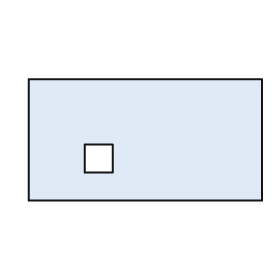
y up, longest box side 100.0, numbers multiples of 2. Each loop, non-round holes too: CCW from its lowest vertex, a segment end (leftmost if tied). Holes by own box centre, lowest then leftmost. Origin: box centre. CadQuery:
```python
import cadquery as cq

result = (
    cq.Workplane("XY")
    .moveTo(-50.0, -26.0)
    .lineTo(50.0, -26.0)
    .lineTo(50.0, 26.0)
    .lineTo(-50.0, 26.0)
    .close()
    .moveTo(-26.0, -14.0)
    .lineTo(-14.0, -14.0)
    .lineTo(-14.0, -2.0)
    .lineTo(-26.0, -2.0)
    .close()
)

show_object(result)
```